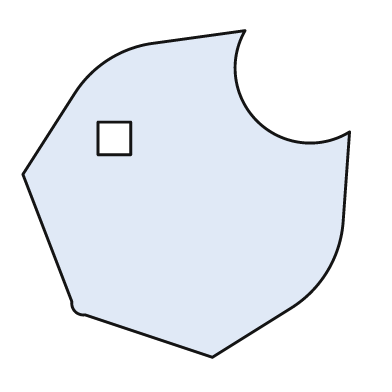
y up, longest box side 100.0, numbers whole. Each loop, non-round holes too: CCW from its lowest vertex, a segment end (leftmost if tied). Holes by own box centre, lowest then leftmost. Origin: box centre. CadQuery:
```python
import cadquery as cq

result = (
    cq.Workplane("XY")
    .moveTo(8.0, -50.0)
    .lineTo(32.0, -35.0)
    .threePointArc((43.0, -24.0), (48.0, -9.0))
    .lineTo(50.0, 19.0)
    .threePointArc((22.0, 22.0), (18.0, 50.0))
    .lineTo(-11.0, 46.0)
    .threePointArc((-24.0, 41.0), (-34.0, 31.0))
    .lineTo(-50.0, 6.0)
    .lineTo(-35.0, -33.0)
    .threePointArc((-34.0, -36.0), (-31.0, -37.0))
    .close()
    .moveTo(-27.0, 12.0)
    .lineTo(-17.0, 12.0)
    .lineTo(-17.0, 22.0)
    .lineTo(-27.0, 22.0)
    .close()
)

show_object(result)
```